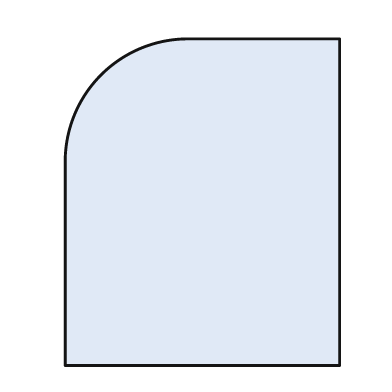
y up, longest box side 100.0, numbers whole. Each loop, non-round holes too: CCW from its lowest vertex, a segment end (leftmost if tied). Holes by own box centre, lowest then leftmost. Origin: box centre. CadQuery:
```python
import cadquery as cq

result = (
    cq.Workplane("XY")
    .moveTo(-42.0, -50.0)
    .lineTo(42.0, -50.0)
    .lineTo(42.0, 50.0)
    .lineTo(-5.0, 50.0)
    .threePointArc((-31.0, 39.0), (-42.0, 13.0))
    .close()
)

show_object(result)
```